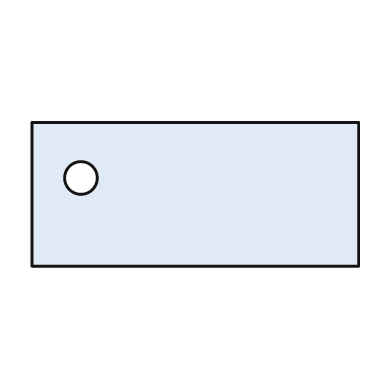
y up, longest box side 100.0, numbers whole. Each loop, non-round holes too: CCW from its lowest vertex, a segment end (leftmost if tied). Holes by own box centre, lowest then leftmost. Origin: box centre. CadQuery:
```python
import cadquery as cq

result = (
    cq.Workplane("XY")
    .moveTo(-50.0, -22.0)
    .lineTo(50.0, -22.0)
    .lineTo(50.0, 22.0)
    .lineTo(-50.0, 22.0)
    .close()
    .moveTo(-35.0, 5.0)
    .circle(5.0)
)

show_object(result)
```